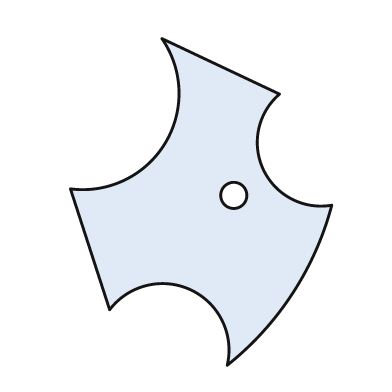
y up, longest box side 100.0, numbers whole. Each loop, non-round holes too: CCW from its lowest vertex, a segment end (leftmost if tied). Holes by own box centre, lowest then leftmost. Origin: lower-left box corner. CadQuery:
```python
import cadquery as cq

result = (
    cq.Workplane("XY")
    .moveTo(48.0, 0.0)
    .threePointArc((68.0, 22.0), (80.0, 49.0))
    .threePointArc((59.0, 60.0), (64.0, 83.0))
    .lineTo(28.0, 100.0)
    .threePointArc((29.0, 68.0), (0.0, 54.0))
    .lineTo(12.0, 17.0)
    .threePointArc((37.0, 23.0), (48.0, 0.0))
    .close()
    .moveTo(50.0, 52.0)
    .circle(4.0)
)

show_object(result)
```